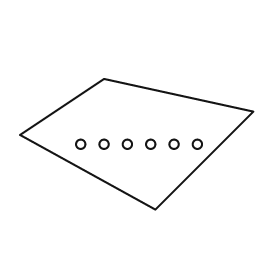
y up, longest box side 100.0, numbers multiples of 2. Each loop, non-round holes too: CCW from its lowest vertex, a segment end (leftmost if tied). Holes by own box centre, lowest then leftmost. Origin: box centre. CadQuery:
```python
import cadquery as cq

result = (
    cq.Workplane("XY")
    .moveTo(8.0, -28.0)
    .lineTo(50.0, 14.0)
    .lineTo(-14.0, 28.0)
    .lineTo(-50.0, 4.0)
    .close()
    .moveTo(-24.0, 0.0)
    .circle(2.0)
    .moveTo(-14.0, 0.0)
    .circle(2.0)
    .moveTo(-4.0, 0.0)
    .circle(2.0)
    .moveTo(6.0, 0.0)
    .circle(2.0)
    .moveTo(16.0, 0.0)
    .circle(2.0)
    .moveTo(26.0, 0.0)
    .circle(2.0)
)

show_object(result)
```